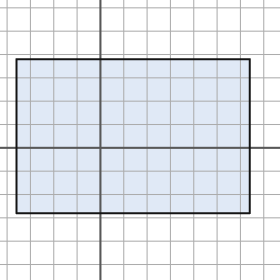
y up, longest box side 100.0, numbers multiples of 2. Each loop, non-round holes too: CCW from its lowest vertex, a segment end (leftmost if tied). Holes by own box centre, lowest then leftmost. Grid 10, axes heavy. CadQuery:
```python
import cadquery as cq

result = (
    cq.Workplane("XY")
    .moveTo(-36.0, -28.0)
    .lineTo(64.0, -28.0)
    .lineTo(64.0, 38.0)
    .lineTo(-36.0, 38.0)
    .close()
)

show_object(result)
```